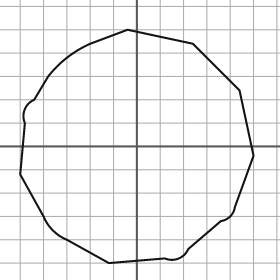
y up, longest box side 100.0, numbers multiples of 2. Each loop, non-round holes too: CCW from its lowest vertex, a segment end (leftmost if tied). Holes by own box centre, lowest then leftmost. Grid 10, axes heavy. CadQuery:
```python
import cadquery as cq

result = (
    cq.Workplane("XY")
    .moveTo(-12.0, -50.0)
    .lineTo(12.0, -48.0)
    .threePointArc((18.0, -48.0), (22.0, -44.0))
    .lineTo(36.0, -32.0)
    .threePointArc((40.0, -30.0), (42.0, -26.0))
    .lineTo(50.0, -4.0)
    .lineTo(44.0, 24.0)
    .lineTo(24.0, 44.0)
    .lineTo(-4.0, 50.0)
    .lineTo(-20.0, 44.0)
    .threePointArc((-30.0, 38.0), (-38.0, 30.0))
    .lineTo(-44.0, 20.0)
    .threePointArc((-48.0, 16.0), (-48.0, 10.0))
    .lineTo(-50.0, -12.0)
    .lineTo(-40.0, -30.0)
    .threePointArc((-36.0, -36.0), (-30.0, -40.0))
    .close()
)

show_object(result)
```